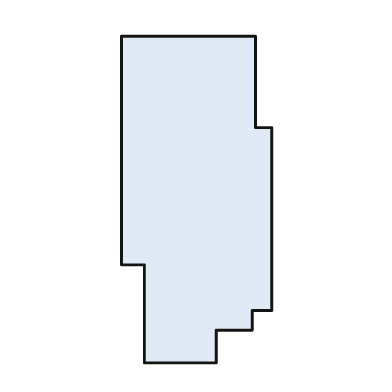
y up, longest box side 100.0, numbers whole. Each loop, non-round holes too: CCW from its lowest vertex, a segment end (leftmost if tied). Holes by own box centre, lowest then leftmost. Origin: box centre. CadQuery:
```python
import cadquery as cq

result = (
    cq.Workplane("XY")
    .moveTo(-16.0, -50.0)
    .lineTo(6.0, -50.0)
    .lineTo(6.0, -40.0)
    .lineTo(17.0, -40.0)
    .lineTo(17.0, -34.0)
    .lineTo(23.0, -34.0)
    .lineTo(23.0, 22.0)
    .lineTo(18.0, 22.0)
    .lineTo(18.0, 50.0)
    .lineTo(-23.0, 50.0)
    .lineTo(-23.0, -20.0)
    .lineTo(-16.0, -20.0)
    .close()
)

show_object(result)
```